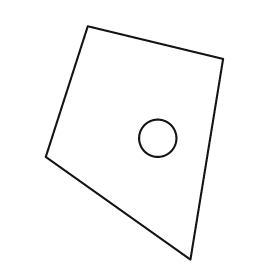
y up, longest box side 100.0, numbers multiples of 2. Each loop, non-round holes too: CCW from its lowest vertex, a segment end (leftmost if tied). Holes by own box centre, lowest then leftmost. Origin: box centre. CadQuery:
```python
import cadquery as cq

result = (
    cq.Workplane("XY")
    .moveTo(24.0, -50.0)
    .lineTo(38.0, 36.0)
    .lineTo(-20.0, 50.0)
    .lineTo(-38.0, -6.0)
    .close()
    .moveTo(10.0, 2.0)
    .circle(8.0)
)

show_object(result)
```